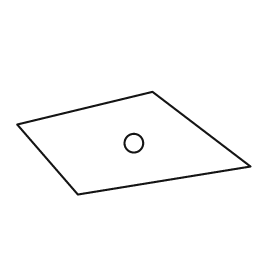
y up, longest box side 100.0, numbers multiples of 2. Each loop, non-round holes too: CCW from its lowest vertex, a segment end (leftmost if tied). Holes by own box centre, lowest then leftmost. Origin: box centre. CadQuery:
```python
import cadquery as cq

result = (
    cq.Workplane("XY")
    .moveTo(-24.0, -22.0)
    .lineTo(50.0, -10.0)
    .lineTo(8.0, 22.0)
    .lineTo(-50.0, 8.0)
    .close()
    .moveTo(0.0, 0.0)
    .circle(4.0)
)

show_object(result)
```